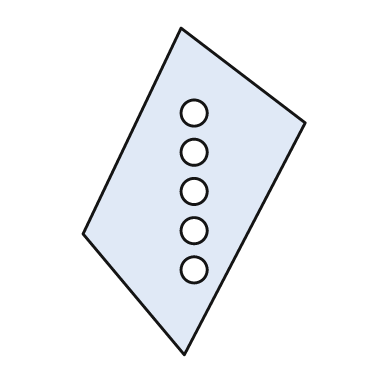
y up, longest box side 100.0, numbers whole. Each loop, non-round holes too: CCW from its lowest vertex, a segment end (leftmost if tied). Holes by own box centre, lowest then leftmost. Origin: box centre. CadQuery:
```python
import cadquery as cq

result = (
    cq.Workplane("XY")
    .moveTo(-3.0, -50.0)
    .lineTo(34.0, 21.0)
    .lineTo(-4.0, 50.0)
    .lineTo(-34.0, -13.0)
    .close()
    .moveTo(0.0, -24.0)
    .circle(4.0)
    .moveTo(0.0, -12.0)
    .circle(4.0)
    .moveTo(0.0, 0.0)
    .circle(4.0)
    .moveTo(0.0, 12.0)
    .circle(4.0)
    .moveTo(0.0, 24.0)
    .circle(4.0)
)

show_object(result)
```